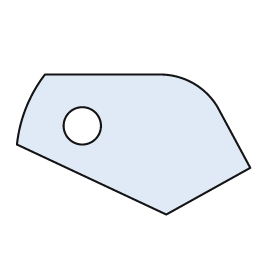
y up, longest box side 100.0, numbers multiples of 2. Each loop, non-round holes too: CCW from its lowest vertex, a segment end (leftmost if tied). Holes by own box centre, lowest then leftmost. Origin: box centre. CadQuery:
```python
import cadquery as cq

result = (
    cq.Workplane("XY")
    .moveTo(14.0, -30.0)
    .lineTo(50.0, -10.0)
    .lineTo(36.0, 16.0)
    .threePointArc((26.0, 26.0), (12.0, 30.0))
    .lineTo(-38.0, 30.0)
    .threePointArc((-46.0, 16.0), (-50.0, 0.0))
    .close()
    .moveTo(-22.0, 8.0)
    .circle(8.0)
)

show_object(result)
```